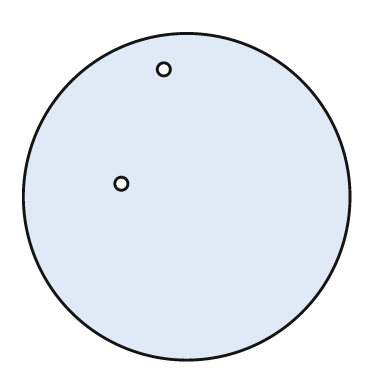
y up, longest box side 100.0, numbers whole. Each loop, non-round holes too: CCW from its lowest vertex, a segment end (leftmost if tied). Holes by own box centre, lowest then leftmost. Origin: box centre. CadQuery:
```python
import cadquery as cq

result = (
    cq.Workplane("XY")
    .moveTo(0.0, 0.0)
    .circle(50.0)
    .moveTo(-20.0, 4.0)
    .circle(2.0)
    .moveTo(-7.0, 39.0)
    .circle(2.0)
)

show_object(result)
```